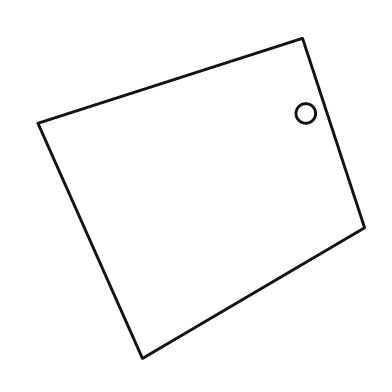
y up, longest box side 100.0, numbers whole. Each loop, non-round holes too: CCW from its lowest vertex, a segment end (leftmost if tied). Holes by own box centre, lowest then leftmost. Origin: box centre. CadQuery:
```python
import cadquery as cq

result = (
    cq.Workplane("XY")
    .moveTo(-18.0, -49.0)
    .lineTo(50.0, -9.0)
    .lineTo(31.0, 49.0)
    .lineTo(-50.0, 23.0)
    .close()
    .moveTo(32.0, 26.0)
    .circle(3.0)
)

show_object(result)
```